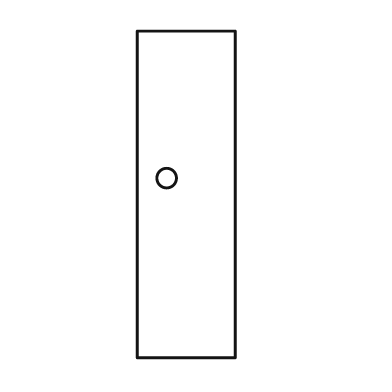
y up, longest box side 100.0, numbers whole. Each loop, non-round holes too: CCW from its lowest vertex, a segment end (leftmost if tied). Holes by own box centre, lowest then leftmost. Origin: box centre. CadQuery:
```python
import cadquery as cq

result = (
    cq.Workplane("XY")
    .moveTo(-15.0, -50.0)
    .lineTo(15.0, -50.0)
    .lineTo(15.0, 50.0)
    .lineTo(-15.0, 50.0)
    .close()
    .moveTo(-6.0, 5.0)
    .circle(3.0)
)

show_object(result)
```